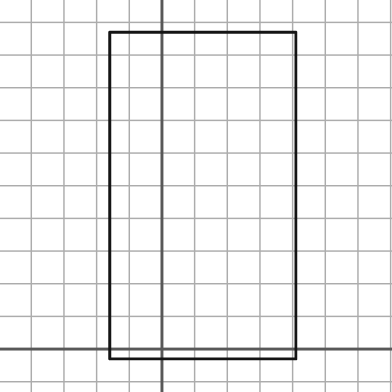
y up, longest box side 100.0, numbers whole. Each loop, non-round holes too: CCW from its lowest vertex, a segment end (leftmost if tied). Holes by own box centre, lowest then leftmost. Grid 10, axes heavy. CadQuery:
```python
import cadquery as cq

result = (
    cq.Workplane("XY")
    .moveTo(-16.0, -3.0)
    .lineTo(41.0, -3.0)
    .lineTo(41.0, 97.0)
    .lineTo(-16.0, 97.0)
    .close()
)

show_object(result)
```